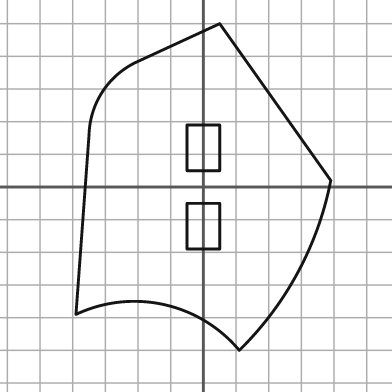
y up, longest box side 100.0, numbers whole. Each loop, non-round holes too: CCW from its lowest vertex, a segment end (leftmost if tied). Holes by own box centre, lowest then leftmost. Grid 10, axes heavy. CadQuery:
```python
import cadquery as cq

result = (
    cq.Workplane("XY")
    .moveTo(11.0, -50.0)
    .threePointArc((29.0, -26.0), (39.0, 2.0))
    .lineTo(5.0, 50.0)
    .lineTo(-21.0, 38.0)
    .threePointArc((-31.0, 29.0), (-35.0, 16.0))
    .lineTo(-39.0, -39.0)
    .threePointArc((-12.0, -36.0), (11.0, -50.0))
    .close()
    .moveTo(-5.0, -19.0)
    .lineTo(5.0, -19.0)
    .lineTo(5.0, -5.0)
    .lineTo(-5.0, -5.0)
    .close()
    .moveTo(-5.0, 5.0)
    .lineTo(5.0, 5.0)
    .lineTo(5.0, 19.0)
    .lineTo(-5.0, 19.0)
    .close()
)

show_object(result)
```